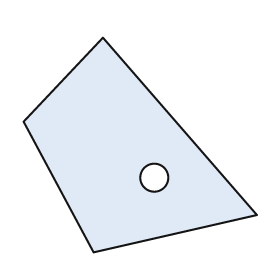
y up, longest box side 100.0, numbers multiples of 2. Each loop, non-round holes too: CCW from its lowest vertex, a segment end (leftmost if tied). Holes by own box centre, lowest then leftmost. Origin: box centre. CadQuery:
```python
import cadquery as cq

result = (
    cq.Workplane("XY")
    .moveTo(-20.0, -46.0)
    .lineTo(50.0, -30.0)
    .lineTo(-16.0, 46.0)
    .lineTo(-50.0, 10.0)
    .close()
    .moveTo(6.0, -14.0)
    .circle(6.0)
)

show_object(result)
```